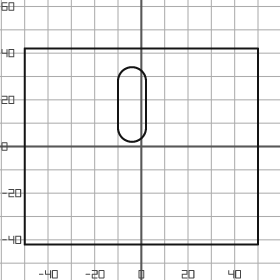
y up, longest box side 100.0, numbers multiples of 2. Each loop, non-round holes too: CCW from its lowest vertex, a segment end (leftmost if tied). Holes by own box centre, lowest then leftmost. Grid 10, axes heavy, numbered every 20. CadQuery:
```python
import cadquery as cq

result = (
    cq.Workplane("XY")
    .moveTo(-50.0, -42.0)
    .lineTo(50.0, -42.0)
    .lineTo(50.0, 42.0)
    .lineTo(-50.0, 42.0)
    .close()
    .moveTo(-10.0, 8.0)
    .threePointArc((-4.0, 2.0), (2.0, 8.0))
    .lineTo(2.0, 28.0)
    .threePointArc((-4.0, 34.0), (-10.0, 28.0))
    .close()
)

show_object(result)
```